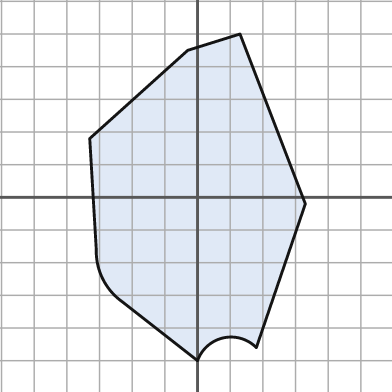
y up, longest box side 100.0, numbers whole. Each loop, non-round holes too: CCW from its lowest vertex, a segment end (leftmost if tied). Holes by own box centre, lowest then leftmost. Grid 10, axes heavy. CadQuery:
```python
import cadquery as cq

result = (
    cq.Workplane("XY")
    .moveTo(0.0, -50.0)
    .threePointArc((8.0, -43.0), (18.0, -46.0))
    .lineTo(33.0, -2.0)
    .lineTo(13.0, 50.0)
    .lineTo(-3.0, 45.0)
    .lineTo(-33.0, 18.0)
    .lineTo(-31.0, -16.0)
    .threePointArc((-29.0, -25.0), (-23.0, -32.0))
    .close()
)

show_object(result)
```